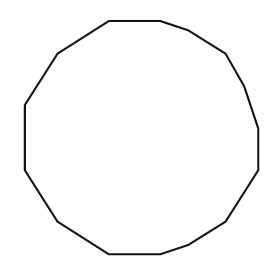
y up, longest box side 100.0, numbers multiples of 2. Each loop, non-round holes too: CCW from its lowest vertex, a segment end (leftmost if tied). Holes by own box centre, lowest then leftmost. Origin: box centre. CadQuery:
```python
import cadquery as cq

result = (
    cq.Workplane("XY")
    .moveTo(-14.0, -50.0)
    .lineTo(8.0, -50.0)
    .lineTo(20.0, -46.0)
    .lineTo(36.0, -36.0)
    .lineTo(50.0, -14.0)
    .lineTo(50.0, 4.0)
    .lineTo(44.0, 22.0)
    .lineTo(36.0, 36.0)
    .lineTo(20.0, 46.0)
    .lineTo(8.0, 50.0)
    .lineTo(-14.0, 50.0)
    .lineTo(-36.0, 36.0)
    .lineTo(-50.0, 14.0)
    .lineTo(-50.0, -14.0)
    .lineTo(-36.0, -36.0)
    .close()
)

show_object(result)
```